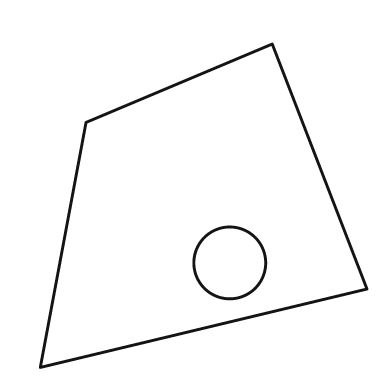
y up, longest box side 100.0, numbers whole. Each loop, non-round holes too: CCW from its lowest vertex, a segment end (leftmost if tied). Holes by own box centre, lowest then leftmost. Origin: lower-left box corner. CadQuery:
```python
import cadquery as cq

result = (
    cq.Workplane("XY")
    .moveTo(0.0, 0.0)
    .lineTo(100.0, 24.0)
    .lineTo(71.0, 99.0)
    .lineTo(14.0, 75.0)
    .close()
    .moveTo(58.0, 32.0)
    .circle(11.0)
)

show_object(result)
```